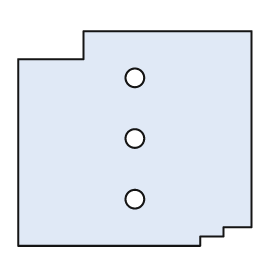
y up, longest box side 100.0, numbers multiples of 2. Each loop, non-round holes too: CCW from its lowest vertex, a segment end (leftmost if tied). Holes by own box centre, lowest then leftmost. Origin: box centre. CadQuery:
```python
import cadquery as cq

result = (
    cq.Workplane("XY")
    .moveTo(-50.0, -46.0)
    .lineTo(28.0, -46.0)
    .lineTo(28.0, -42.0)
    .lineTo(38.0, -42.0)
    .lineTo(38.0, -38.0)
    .lineTo(50.0, -38.0)
    .lineTo(50.0, 46.0)
    .lineTo(-22.0, 46.0)
    .lineTo(-22.0, 34.0)
    .lineTo(-50.0, 34.0)
    .close()
    .moveTo(0.0, -26.0)
    .circle(4.0)
    .moveTo(0.0, 0.0)
    .circle(4.0)
    .moveTo(0.0, 26.0)
    .circle(4.0)
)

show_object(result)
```